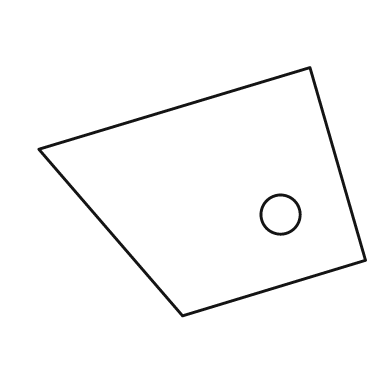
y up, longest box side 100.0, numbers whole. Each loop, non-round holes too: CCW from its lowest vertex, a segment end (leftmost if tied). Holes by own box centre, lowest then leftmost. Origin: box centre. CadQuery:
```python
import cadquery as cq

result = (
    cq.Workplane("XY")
    .moveTo(-6.0, -38.0)
    .lineTo(50.0, -21.0)
    .lineTo(33.0, 38.0)
    .lineTo(-50.0, 13.0)
    .close()
    .moveTo(24.0, -7.0)
    .circle(6.0)
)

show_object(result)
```